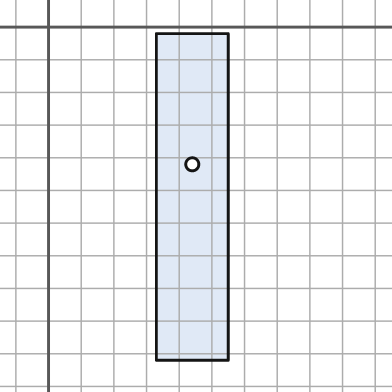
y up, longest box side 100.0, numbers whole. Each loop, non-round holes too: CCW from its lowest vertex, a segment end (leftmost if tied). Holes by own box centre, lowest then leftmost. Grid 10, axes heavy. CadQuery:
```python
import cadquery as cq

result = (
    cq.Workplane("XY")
    .moveTo(33.0, -102.0)
    .lineTo(55.0, -102.0)
    .lineTo(55.0, -2.0)
    .lineTo(33.0, -2.0)
    .close()
    .moveTo(44.0, -42.0)
    .circle(2.0)
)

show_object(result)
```